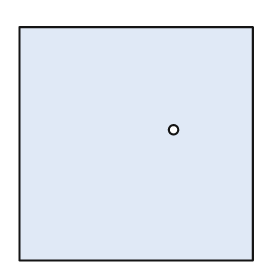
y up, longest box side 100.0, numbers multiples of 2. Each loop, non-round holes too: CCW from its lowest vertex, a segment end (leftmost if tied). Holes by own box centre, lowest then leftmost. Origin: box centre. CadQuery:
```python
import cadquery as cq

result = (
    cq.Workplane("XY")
    .moveTo(-50.0, -50.0)
    .lineTo(50.0, -50.0)
    .lineTo(50.0, 50.0)
    .lineTo(-50.0, 50.0)
    .close()
    .moveTo(16.0, 6.0)
    .circle(2.0)
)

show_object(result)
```